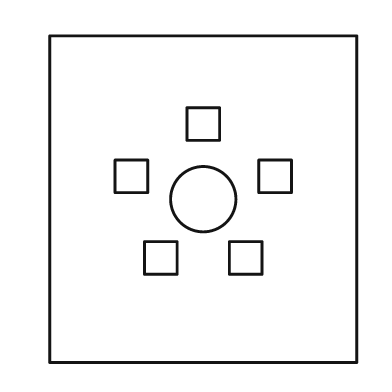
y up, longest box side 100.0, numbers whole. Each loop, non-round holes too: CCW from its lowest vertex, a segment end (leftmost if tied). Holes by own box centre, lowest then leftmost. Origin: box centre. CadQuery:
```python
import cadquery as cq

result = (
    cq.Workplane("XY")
    .moveTo(-47.0, -50.0)
    .lineTo(47.0, -50.0)
    .lineTo(47.0, 50.0)
    .lineTo(-47.0, 50.0)
    .close()
    .moveTo(-18.0, -23.0)
    .lineTo(-8.0, -23.0)
    .lineTo(-8.0, -13.0)
    .lineTo(-18.0, -13.0)
    .close()
    .moveTo(8.0, -23.0)
    .lineTo(18.0, -23.0)
    .lineTo(18.0, -13.0)
    .lineTo(8.0, -13.0)
    .close()
    .moveTo(0.0, 0.0)
    .circle(10.0)
    .moveTo(-27.0, 2.0)
    .lineTo(-17.0, 2.0)
    .lineTo(-17.0, 12.0)
    .lineTo(-27.0, 12.0)
    .close()
    .moveTo(17.0, 2.0)
    .lineTo(27.0, 2.0)
    .lineTo(27.0, 12.0)
    .lineTo(17.0, 12.0)
    .close()
    .moveTo(-5.0, 18.0)
    .lineTo(5.0, 18.0)
    .lineTo(5.0, 28.0)
    .lineTo(-5.0, 28.0)
    .close()
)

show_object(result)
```